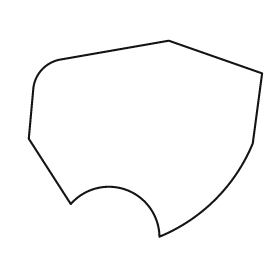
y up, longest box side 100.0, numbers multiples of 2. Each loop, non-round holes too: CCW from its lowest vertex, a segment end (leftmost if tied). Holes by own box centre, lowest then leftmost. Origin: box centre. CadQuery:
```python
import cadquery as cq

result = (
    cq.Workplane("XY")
    .moveTo(6.0, -42.0)
    .threePointArc((30.0, -26.0), (46.0, -2.0))
    .lineTo(50.0, 28.0)
    .lineTo(10.0, 42.0)
    .lineTo(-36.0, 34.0)
    .threePointArc((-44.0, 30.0), (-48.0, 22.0))
    .lineTo(-50.0, 0.0)
    .lineTo(-32.0, -28.0)
    .threePointArc((-8.0, -22.0), (6.0, -42.0))
    .close()
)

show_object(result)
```